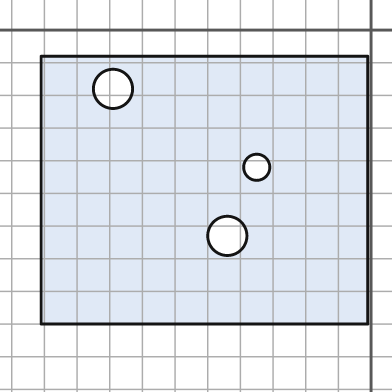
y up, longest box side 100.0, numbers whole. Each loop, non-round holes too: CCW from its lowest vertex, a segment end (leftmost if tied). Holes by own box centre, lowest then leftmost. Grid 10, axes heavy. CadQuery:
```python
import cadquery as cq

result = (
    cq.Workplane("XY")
    .moveTo(-101.0, -90.0)
    .lineTo(-1.0, -90.0)
    .lineTo(-1.0, -8.0)
    .lineTo(-101.0, -8.0)
    .close()
    .moveTo(-44.0, -63.0)
    .circle(6.0)
    .moveTo(-35.0, -42.0)
    .circle(4.0)
    .moveTo(-79.0, -18.0)
    .circle(6.0)
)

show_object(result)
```